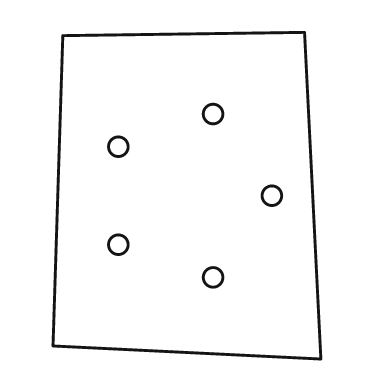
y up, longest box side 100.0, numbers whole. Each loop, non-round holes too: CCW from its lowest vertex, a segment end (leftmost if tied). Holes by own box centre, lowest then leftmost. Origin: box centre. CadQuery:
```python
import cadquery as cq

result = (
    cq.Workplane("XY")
    .moveTo(41.0, -50.0)
    .lineTo(36.0, 50.0)
    .lineTo(-38.0, 49.0)
    .lineTo(-41.0, -46.0)
    .close()
    .moveTo(8.0, -25.0)
    .circle(3.0)
    .moveTo(-21.0, -15.0)
    .circle(3.0)
    .moveTo(26.0, 0.0)
    .circle(3.0)
    .moveTo(-21.0, 15.0)
    .circle(3.0)
    .moveTo(8.0, 25.0)
    .circle(3.0)
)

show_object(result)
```